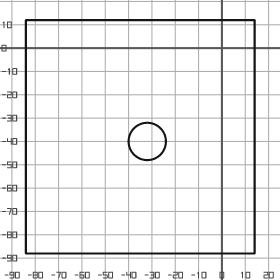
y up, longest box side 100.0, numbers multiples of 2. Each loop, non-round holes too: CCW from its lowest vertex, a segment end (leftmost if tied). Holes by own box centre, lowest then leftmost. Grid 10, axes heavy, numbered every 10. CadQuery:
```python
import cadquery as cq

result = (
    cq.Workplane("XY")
    .moveTo(-84.0, -88.0)
    .lineTo(14.0, -88.0)
    .lineTo(14.0, 12.0)
    .lineTo(-84.0, 12.0)
    .close()
    .moveTo(-32.0, -40.0)
    .circle(8.0)
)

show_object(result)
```